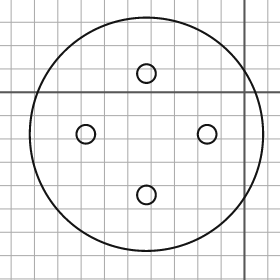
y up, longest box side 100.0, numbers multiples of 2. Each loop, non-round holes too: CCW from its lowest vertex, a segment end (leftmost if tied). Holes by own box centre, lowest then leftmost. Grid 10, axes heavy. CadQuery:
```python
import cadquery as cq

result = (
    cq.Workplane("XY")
    .moveTo(-42.0, -18.0)
    .circle(50.0)
    .moveTo(-42.0, -44.0)
    .circle(4.0)
    .moveTo(-68.0, -18.0)
    .circle(4.0)
    .moveTo(-16.0, -18.0)
    .circle(4.0)
    .moveTo(-42.0, 8.0)
    .circle(4.0)
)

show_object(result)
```